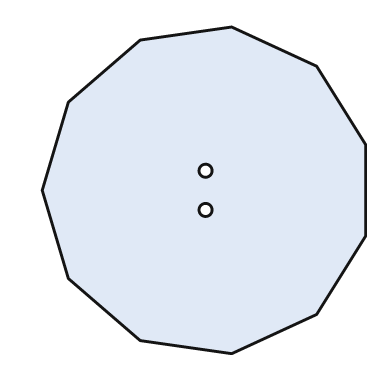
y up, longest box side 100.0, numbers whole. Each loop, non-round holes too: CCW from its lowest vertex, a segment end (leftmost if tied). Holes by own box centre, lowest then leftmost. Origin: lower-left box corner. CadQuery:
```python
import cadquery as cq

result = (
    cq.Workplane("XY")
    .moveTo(58.0, 0.0)
    .lineTo(84.0, 12.0)
    .lineTo(99.0, 36.0)
    .lineTo(99.0, 64.0)
    .lineTo(84.0, 88.0)
    .lineTo(58.0, 100.0)
    .lineTo(30.0, 96.0)
    .lineTo(8.0, 77.0)
    .lineTo(0.0, 50.0)
    .lineTo(8.0, 23.0)
    .lineTo(30.0, 4.0)
    .close()
    .moveTo(50.0, 44.0)
    .circle(2.0)
    .moveTo(50.0, 56.0)
    .circle(2.0)
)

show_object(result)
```